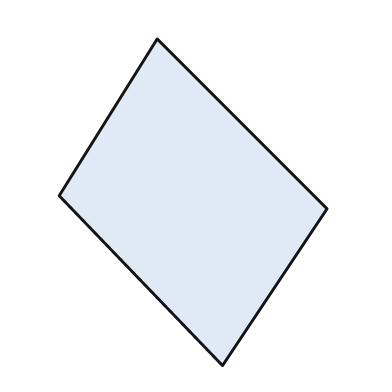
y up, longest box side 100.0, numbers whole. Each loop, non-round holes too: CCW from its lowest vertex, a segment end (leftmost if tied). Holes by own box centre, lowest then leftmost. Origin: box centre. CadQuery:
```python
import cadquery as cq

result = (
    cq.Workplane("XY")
    .moveTo(9.0, -50.0)
    .lineTo(41.0, -2.0)
    .lineTo(-11.0, 50.0)
    .lineTo(-41.0, 2.0)
    .close()
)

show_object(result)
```